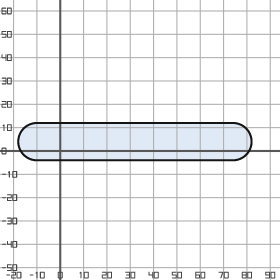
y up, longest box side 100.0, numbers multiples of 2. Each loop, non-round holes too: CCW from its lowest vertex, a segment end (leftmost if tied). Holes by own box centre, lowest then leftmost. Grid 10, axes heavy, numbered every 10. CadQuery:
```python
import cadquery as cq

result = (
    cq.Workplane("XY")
    .moveTo(-10.0, -4.0)
    .lineTo(74.0, -4.0)
    .threePointArc((82.0, 4.0), (74.0, 12.0))
    .lineTo(-10.0, 12.0)
    .threePointArc((-18.0, 4.0), (-10.0, -4.0))
    .close()
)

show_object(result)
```